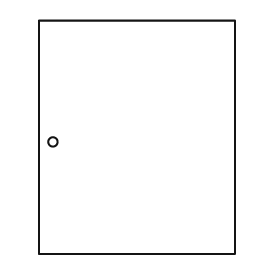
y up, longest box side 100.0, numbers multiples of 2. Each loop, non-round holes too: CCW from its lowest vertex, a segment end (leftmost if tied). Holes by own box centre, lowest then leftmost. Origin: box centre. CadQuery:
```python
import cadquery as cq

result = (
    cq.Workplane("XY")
    .moveTo(-42.0, -50.0)
    .lineTo(42.0, -50.0)
    .lineTo(42.0, 50.0)
    .lineTo(-42.0, 50.0)
    .close()
    .moveTo(-36.0, -2.0)
    .circle(2.0)
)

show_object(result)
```